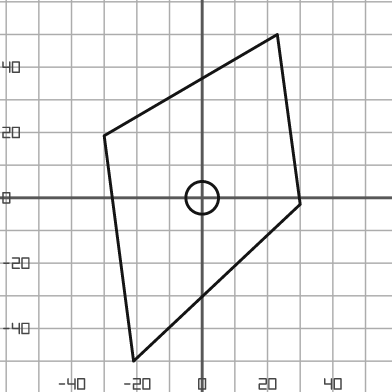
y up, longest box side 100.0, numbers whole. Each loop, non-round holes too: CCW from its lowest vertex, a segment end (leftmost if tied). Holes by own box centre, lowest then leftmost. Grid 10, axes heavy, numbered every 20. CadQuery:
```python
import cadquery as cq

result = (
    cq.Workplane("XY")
    .moveTo(-21.0, -50.0)
    .lineTo(30.0, -2.0)
    .lineTo(23.0, 50.0)
    .lineTo(-30.0, 19.0)
    .close()
    .moveTo(0.0, 0.0)
    .circle(5.0)
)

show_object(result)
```